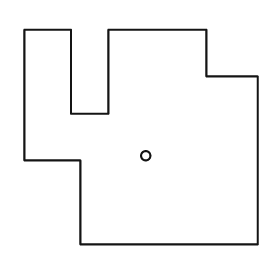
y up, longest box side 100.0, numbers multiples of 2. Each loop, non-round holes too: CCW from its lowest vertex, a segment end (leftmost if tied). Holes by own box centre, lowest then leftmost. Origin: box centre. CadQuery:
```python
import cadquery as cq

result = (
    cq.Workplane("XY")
    .moveTo(-26.0, -46.0)
    .lineTo(50.0, -46.0)
    .lineTo(50.0, 26.0)
    .lineTo(28.0, 26.0)
    .lineTo(28.0, 46.0)
    .lineTo(-14.0, 46.0)
    .lineTo(-14.0, 10.0)
    .lineTo(-30.0, 10.0)
    .lineTo(-30.0, 46.0)
    .lineTo(-50.0, 46.0)
    .lineTo(-50.0, -10.0)
    .lineTo(-26.0, -10.0)
    .close()
    .moveTo(2.0, -8.0)
    .circle(2.0)
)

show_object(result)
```